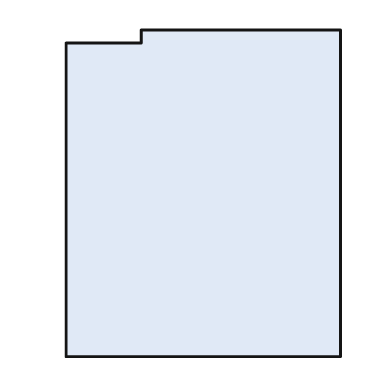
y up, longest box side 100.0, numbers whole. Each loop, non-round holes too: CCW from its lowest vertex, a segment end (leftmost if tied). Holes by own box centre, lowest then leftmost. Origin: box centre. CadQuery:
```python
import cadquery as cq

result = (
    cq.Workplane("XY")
    .moveTo(-42.0, -50.0)
    .lineTo(42.0, -50.0)
    .lineTo(42.0, 50.0)
    .lineTo(-19.0, 50.0)
    .lineTo(-19.0, 46.0)
    .lineTo(-42.0, 46.0)
    .close()
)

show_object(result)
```